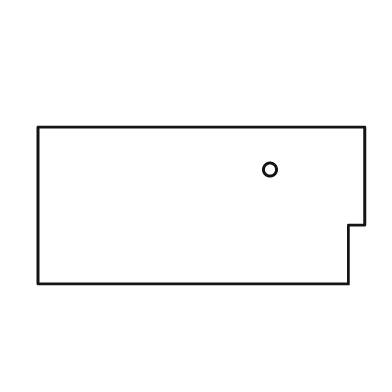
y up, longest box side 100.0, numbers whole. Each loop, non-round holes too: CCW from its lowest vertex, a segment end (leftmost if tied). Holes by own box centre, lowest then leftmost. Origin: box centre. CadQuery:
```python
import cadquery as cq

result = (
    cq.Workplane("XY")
    .moveTo(-50.0, -24.0)
    .lineTo(45.0, -24.0)
    .lineTo(45.0, -6.0)
    .lineTo(50.0, -6.0)
    .lineTo(50.0, 24.0)
    .lineTo(-50.0, 24.0)
    .close()
    .moveTo(21.0, 11.0)
    .circle(2.0)
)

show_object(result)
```